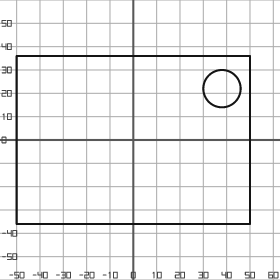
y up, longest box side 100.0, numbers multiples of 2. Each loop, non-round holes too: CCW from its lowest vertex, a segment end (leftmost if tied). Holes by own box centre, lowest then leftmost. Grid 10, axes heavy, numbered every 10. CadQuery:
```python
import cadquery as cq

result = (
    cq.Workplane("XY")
    .moveTo(-50.0, -36.0)
    .lineTo(50.0, -36.0)
    .lineTo(50.0, 36.0)
    .lineTo(-50.0, 36.0)
    .close()
    .moveTo(38.0, 22.0)
    .circle(8.0)
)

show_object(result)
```